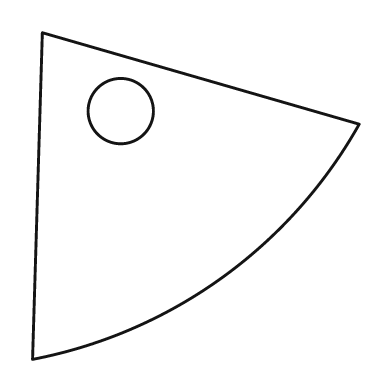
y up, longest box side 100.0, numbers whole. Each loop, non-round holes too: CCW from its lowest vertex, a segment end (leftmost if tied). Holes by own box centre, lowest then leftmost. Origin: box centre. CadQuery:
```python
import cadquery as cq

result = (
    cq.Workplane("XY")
    .moveTo(-50.0, -50.0)
    .threePointArc((8.0, -25.0), (50.0, 22.0))
    .lineTo(-47.0, 50.0)
    .close()
    .moveTo(-23.0, 26.0)
    .circle(10.0)
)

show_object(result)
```